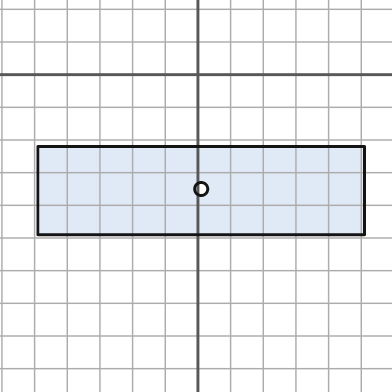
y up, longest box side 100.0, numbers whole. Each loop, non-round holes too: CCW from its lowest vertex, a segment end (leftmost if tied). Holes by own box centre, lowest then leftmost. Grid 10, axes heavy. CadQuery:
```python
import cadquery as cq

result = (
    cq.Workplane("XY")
    .moveTo(-49.0, -49.0)
    .lineTo(51.0, -49.0)
    .lineTo(51.0, -22.0)
    .lineTo(-49.0, -22.0)
    .close()
    .moveTo(1.0, -35.0)
    .circle(2.0)
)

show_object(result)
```